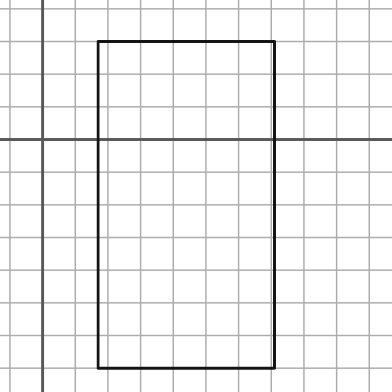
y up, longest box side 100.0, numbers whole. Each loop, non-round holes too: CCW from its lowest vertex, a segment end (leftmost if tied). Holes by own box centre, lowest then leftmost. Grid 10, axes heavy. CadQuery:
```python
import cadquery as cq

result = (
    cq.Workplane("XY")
    .moveTo(17.0, -70.0)
    .lineTo(71.0, -70.0)
    .lineTo(71.0, 30.0)
    .lineTo(17.0, 30.0)
    .close()
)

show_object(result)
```